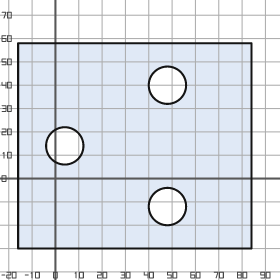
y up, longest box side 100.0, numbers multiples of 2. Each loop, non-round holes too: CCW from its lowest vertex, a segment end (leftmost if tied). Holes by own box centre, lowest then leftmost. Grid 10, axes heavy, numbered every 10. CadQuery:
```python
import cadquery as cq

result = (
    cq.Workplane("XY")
    .moveTo(-16.0, -30.0)
    .lineTo(84.0, -30.0)
    .lineTo(84.0, 58.0)
    .lineTo(-16.0, 58.0)
    .close()
    .moveTo(48.0, -12.0)
    .circle(8.0)
    .moveTo(4.0, 14.0)
    .circle(8.0)
    .moveTo(48.0, 40.0)
    .circle(8.0)
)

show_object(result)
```